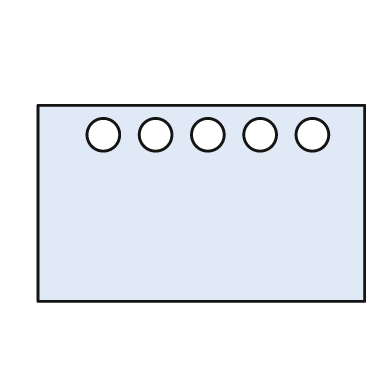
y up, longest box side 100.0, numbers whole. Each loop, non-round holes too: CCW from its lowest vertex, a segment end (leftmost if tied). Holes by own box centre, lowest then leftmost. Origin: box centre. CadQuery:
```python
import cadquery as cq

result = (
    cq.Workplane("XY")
    .moveTo(-50.0, -30.0)
    .lineTo(50.0, -30.0)
    .lineTo(50.0, 30.0)
    .lineTo(-50.0, 30.0)
    .close()
    .moveTo(-30.0, 21.0)
    .circle(5.0)
    .moveTo(-14.0, 21.0)
    .circle(5.0)
    .moveTo(2.0, 21.0)
    .circle(5.0)
    .moveTo(18.0, 21.0)
    .circle(5.0)
    .moveTo(34.0, 21.0)
    .circle(5.0)
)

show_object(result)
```